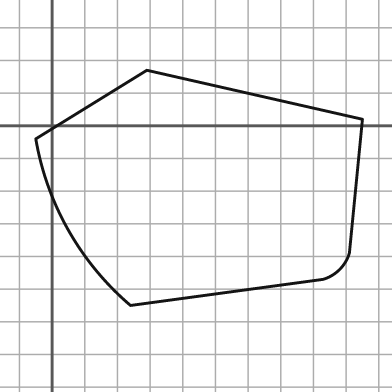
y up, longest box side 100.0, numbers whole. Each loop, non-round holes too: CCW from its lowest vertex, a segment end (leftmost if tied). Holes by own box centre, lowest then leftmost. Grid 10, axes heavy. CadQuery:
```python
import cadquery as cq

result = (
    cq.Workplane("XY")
    .moveTo(24.0, -55.0)
    .lineTo(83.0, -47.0)
    .threePointArc((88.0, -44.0), (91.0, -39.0))
    .lineTo(95.0, 2.0)
    .lineTo(29.0, 17.0)
    .lineTo(-5.0, -4.0)
    .threePointArc((5.0, -32.0), (24.0, -55.0))
    .close()
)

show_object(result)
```